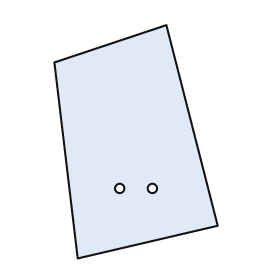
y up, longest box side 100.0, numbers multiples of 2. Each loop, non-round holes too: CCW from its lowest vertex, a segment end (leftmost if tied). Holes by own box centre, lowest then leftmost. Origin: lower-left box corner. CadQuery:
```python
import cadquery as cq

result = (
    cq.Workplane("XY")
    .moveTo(10.0, 0.0)
    .lineTo(70.0, 14.0)
    .lineTo(48.0, 100.0)
    .lineTo(0.0, 84.0)
    .close()
    .moveTo(28.0, 30.0)
    .circle(2.0)
    .moveTo(42.0, 30.0)
    .circle(2.0)
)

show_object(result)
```